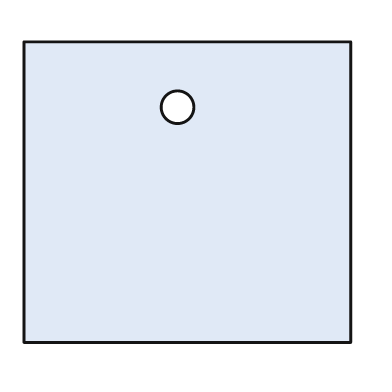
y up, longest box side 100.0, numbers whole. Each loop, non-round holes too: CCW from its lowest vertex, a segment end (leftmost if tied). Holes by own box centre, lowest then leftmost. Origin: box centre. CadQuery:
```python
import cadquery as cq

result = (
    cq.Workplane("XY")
    .moveTo(-50.0, -46.0)
    .lineTo(50.0, -46.0)
    .lineTo(50.0, 46.0)
    .lineTo(-50.0, 46.0)
    .close()
    .moveTo(-3.0, 26.0)
    .circle(5.0)
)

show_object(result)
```